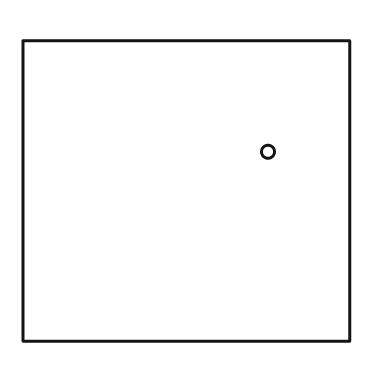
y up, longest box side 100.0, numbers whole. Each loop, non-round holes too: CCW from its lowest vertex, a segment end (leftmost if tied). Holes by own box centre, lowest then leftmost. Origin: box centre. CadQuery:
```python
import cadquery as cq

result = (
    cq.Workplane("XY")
    .moveTo(-50.0, -46.0)
    .lineTo(50.0, -46.0)
    .lineTo(50.0, 46.0)
    .lineTo(-50.0, 46.0)
    .close()
    .moveTo(25.0, 12.0)
    .circle(2.0)
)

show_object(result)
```